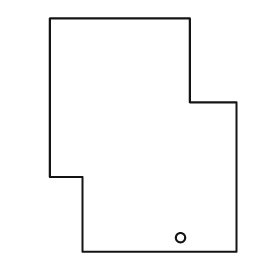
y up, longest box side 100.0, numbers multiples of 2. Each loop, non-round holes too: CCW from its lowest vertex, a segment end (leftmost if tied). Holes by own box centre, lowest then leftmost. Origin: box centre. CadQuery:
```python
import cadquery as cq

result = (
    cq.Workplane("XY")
    .moveTo(-26.0, -50.0)
    .lineTo(40.0, -50.0)
    .lineTo(40.0, 14.0)
    .lineTo(20.0, 14.0)
    .lineTo(20.0, 50.0)
    .lineTo(-40.0, 50.0)
    .lineTo(-40.0, -18.0)
    .lineTo(-26.0, -18.0)
    .close()
    .moveTo(16.0, -44.0)
    .circle(2.0)
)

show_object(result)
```